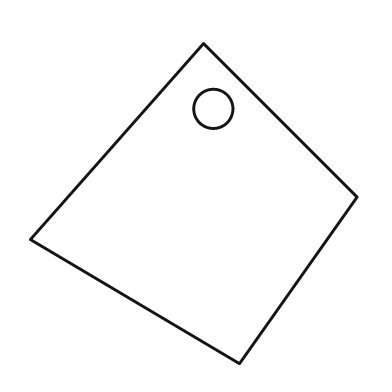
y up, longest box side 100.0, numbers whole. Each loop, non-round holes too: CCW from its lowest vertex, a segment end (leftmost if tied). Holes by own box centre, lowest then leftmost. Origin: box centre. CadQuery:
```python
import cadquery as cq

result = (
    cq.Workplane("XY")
    .moveTo(14.0, -49.0)
    .lineTo(50.0, 2.0)
    .lineTo(3.0, 49.0)
    .lineTo(-50.0, -11.0)
    .close()
    .moveTo(6.0, 29.0)
    .circle(6.0)
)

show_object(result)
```